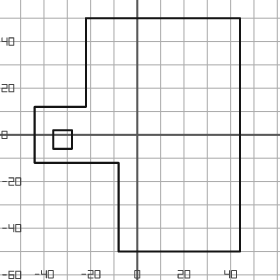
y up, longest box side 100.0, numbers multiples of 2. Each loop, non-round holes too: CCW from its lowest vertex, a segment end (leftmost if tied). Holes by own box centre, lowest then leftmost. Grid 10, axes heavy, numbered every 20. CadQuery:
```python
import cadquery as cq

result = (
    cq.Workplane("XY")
    .moveTo(-8.0, -50.0)
    .lineTo(44.0, -50.0)
    .lineTo(44.0, 50.0)
    .lineTo(-22.0, 50.0)
    .lineTo(-22.0, 12.0)
    .lineTo(-44.0, 12.0)
    .lineTo(-44.0, -12.0)
    .lineTo(-8.0, -12.0)
    .close()
    .moveTo(-36.0, -6.0)
    .lineTo(-28.0, -6.0)
    .lineTo(-28.0, 2.0)
    .lineTo(-36.0, 2.0)
    .close()
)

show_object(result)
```